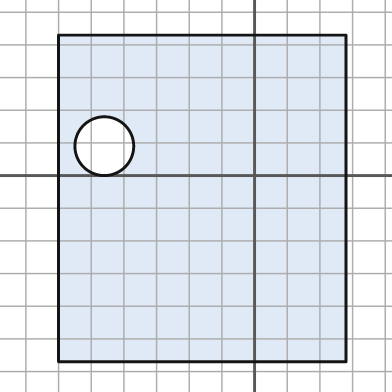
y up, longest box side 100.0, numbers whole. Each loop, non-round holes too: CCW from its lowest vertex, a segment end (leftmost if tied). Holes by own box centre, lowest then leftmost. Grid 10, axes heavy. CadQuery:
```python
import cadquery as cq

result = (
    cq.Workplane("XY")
    .moveTo(-60.0, -57.0)
    .lineTo(28.0, -57.0)
    .lineTo(28.0, 43.0)
    .lineTo(-60.0, 43.0)
    .close()
    .moveTo(-46.0, 9.0)
    .circle(9.0)
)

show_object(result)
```